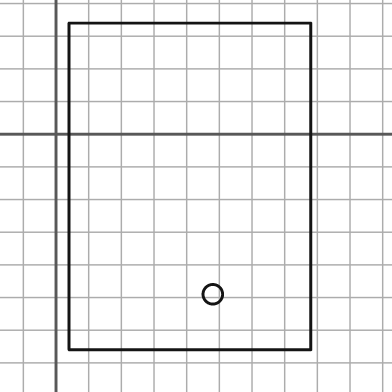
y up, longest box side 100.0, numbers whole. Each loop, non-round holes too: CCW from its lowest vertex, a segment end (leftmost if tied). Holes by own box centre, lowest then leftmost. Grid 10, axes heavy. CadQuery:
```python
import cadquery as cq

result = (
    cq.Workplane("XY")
    .moveTo(4.0, -66.0)
    .lineTo(78.0, -66.0)
    .lineTo(78.0, 34.0)
    .lineTo(4.0, 34.0)
    .close()
    .moveTo(48.0, -49.0)
    .circle(3.0)
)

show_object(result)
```